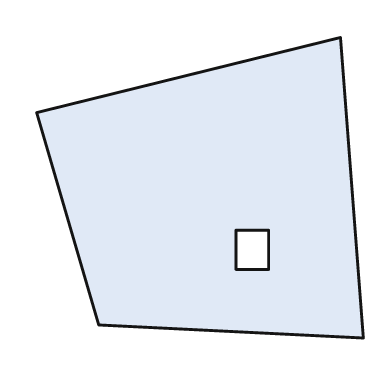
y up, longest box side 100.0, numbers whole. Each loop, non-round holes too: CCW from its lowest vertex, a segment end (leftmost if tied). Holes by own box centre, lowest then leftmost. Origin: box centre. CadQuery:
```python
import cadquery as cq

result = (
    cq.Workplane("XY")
    .moveTo(50.0, -46.0)
    .lineTo(43.0, 46.0)
    .lineTo(-50.0, 23.0)
    .lineTo(-31.0, -42.0)
    .close()
    .moveTo(11.0, -25.0)
    .lineTo(21.0, -25.0)
    .lineTo(21.0, -13.0)
    .lineTo(11.0, -13.0)
    .close()
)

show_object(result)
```